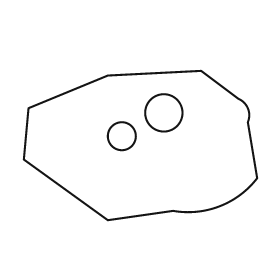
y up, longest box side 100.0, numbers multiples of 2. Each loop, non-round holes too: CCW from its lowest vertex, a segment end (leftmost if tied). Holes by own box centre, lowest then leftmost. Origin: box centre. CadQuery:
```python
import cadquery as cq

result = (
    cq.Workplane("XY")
    .moveTo(-14.0, -32.0)
    .lineTo(14.0, -28.0)
    .threePointArc((34.0, -26.0), (50.0, -14.0))
    .lineTo(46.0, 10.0)
    .threePointArc((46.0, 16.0), (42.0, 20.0))
    .lineTo(26.0, 32.0)
    .lineTo(-14.0, 30.0)
    .lineTo(-48.0, 16.0)
    .lineTo(-50.0, -6.0)
    .close()
    .moveTo(-8.0, 4.0)
    .circle(6.0)
    .moveTo(10.0, 14.0)
    .circle(8.0)
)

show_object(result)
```